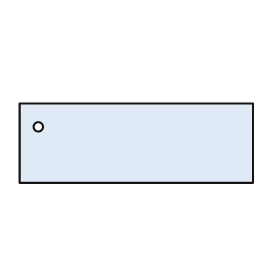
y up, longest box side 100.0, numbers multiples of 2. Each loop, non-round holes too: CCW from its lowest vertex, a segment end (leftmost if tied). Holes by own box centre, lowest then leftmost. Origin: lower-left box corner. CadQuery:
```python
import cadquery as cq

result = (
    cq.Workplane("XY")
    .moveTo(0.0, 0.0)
    .lineTo(100.0, 0.0)
    .lineTo(100.0, 34.0)
    .lineTo(0.0, 34.0)
    .close()
    .moveTo(8.0, 24.0)
    .circle(2.0)
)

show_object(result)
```